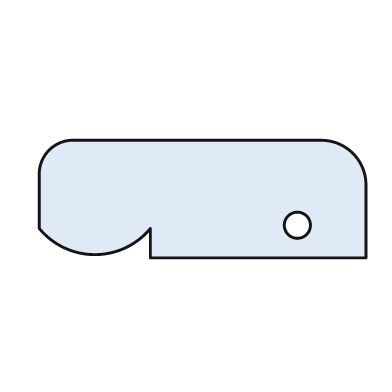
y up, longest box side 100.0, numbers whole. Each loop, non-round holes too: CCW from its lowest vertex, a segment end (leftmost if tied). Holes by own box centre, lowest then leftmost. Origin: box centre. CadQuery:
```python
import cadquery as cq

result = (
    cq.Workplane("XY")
    .moveTo(-16.0, -18.0)
    .lineTo(50.0, -18.0)
    .lineTo(50.0, 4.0)
    .threePointArc((46.0, 14.0), (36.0, 18.0))
    .lineTo(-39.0, 18.0)
    .threePointArc((-47.0, 15.0), (-50.0, 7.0))
    .lineTo(-50.0, -9.0)
    .threePointArc((-33.0, -17.0), (-16.0, -9.0))
    .close()
    .moveTo(29.0, -8.0)
    .circle(4.0)
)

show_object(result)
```